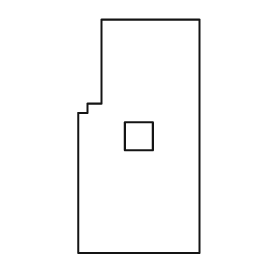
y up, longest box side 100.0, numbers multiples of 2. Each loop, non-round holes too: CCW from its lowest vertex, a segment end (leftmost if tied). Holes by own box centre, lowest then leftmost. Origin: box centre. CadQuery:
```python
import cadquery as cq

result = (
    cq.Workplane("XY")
    .moveTo(-26.0, -50.0)
    .lineTo(26.0, -50.0)
    .lineTo(26.0, 50.0)
    .lineTo(-16.0, 50.0)
    .lineTo(-16.0, 14.0)
    .lineTo(-22.0, 14.0)
    .lineTo(-22.0, 10.0)
    .lineTo(-26.0, 10.0)
    .close()
    .moveTo(-6.0, -6.0)
    .lineTo(6.0, -6.0)
    .lineTo(6.0, 6.0)
    .lineTo(-6.0, 6.0)
    .close()
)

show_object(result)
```